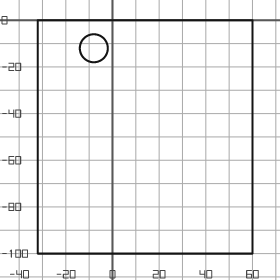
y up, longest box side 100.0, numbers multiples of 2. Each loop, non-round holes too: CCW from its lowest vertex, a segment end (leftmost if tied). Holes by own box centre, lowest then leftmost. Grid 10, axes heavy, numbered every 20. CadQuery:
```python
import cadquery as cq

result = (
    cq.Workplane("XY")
    .moveTo(-32.0, -100.0)
    .lineTo(60.0, -100.0)
    .lineTo(60.0, 0.0)
    .lineTo(-32.0, 0.0)
    .close()
    .moveTo(-8.0, -12.0)
    .circle(6.0)
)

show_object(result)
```